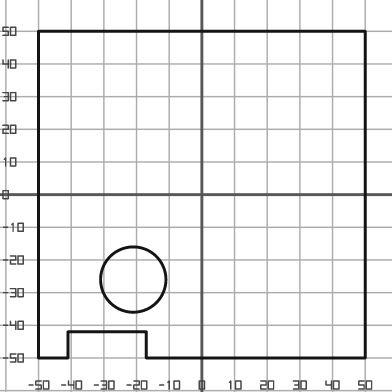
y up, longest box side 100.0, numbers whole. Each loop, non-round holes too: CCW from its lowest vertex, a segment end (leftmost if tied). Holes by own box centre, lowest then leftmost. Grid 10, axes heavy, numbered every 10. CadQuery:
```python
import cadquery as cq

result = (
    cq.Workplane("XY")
    .moveTo(-50.0, -50.0)
    .lineTo(-41.0, -50.0)
    .lineTo(-41.0, -42.0)
    .lineTo(-17.0, -42.0)
    .lineTo(-17.0, -50.0)
    .lineTo(50.0, -50.0)
    .lineTo(50.0, 50.0)
    .lineTo(-50.0, 50.0)
    .close()
    .moveTo(-21.0, -26.0)
    .circle(10.0)
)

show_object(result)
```